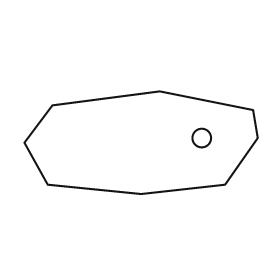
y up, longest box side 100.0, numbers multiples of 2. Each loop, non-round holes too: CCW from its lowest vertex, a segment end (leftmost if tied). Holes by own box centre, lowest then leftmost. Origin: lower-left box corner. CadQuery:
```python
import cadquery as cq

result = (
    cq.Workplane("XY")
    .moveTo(50.0, 0.0)
    .lineTo(86.0, 4.0)
    .lineTo(100.0, 24.0)
    .lineTo(98.0, 36.0)
    .lineTo(58.0, 44.0)
    .lineTo(12.0, 38.0)
    .lineTo(0.0, 22.0)
    .lineTo(10.0, 4.0)
    .close()
    .moveTo(76.0, 24.0)
    .circle(4.0)
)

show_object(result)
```